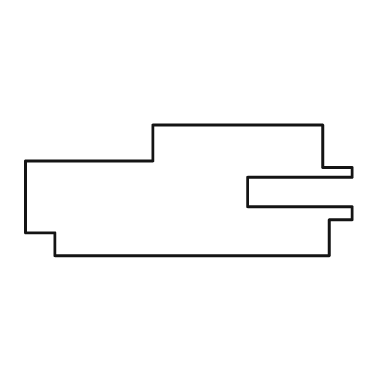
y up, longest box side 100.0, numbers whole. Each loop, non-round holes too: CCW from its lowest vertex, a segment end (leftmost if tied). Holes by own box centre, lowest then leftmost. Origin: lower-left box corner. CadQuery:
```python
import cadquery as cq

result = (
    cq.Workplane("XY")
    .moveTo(9.0, 0.0)
    .lineTo(93.0, 0.0)
    .lineTo(93.0, 11.0)
    .lineTo(100.0, 11.0)
    .lineTo(100.0, 15.0)
    .lineTo(68.0, 15.0)
    .lineTo(68.0, 24.0)
    .lineTo(100.0, 24.0)
    .lineTo(100.0, 27.0)
    .lineTo(91.0, 27.0)
    .lineTo(91.0, 40.0)
    .lineTo(39.0, 40.0)
    .lineTo(39.0, 29.0)
    .lineTo(0.0, 29.0)
    .lineTo(0.0, 7.0)
    .lineTo(9.0, 7.0)
    .close()
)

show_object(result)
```